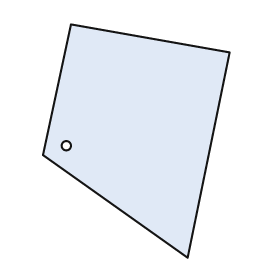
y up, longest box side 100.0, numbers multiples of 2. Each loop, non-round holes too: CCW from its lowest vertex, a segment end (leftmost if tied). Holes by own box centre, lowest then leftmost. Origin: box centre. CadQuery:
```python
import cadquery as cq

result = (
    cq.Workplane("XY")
    .moveTo(22.0, -50.0)
    .lineTo(40.0, 38.0)
    .lineTo(-28.0, 50.0)
    .lineTo(-40.0, -6.0)
    .close()
    .moveTo(-30.0, -2.0)
    .circle(2.0)
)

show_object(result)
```